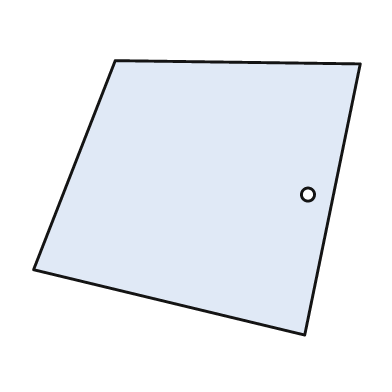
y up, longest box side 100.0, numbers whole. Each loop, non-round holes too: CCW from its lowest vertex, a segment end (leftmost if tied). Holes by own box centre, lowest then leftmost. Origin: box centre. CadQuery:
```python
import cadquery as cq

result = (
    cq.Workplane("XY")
    .moveTo(33.0, -42.0)
    .lineTo(50.0, 41.0)
    .lineTo(-25.0, 42.0)
    .lineTo(-50.0, -22.0)
    .close()
    .moveTo(34.0, 1.0)
    .circle(2.0)
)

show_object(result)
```